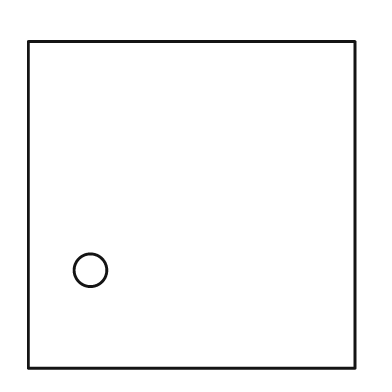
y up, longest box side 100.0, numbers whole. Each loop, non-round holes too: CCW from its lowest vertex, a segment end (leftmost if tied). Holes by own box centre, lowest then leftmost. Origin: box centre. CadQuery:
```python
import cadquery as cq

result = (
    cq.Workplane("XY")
    .moveTo(-50.0, -50.0)
    .lineTo(50.0, -50.0)
    .lineTo(50.0, 50.0)
    .lineTo(-50.0, 50.0)
    .close()
    .moveTo(-31.0, -20.0)
    .circle(5.0)
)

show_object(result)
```